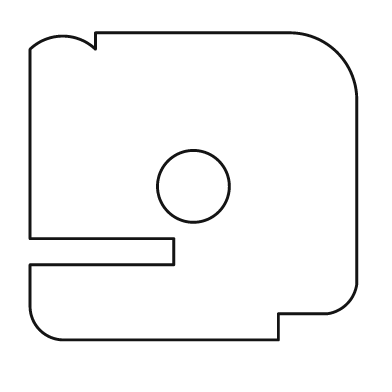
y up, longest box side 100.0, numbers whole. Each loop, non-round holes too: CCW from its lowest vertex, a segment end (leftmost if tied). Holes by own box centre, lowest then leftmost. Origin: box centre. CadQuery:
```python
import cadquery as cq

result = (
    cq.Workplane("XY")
    .moveTo(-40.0, -47.0)
    .lineTo(26.0, -47.0)
    .lineTo(26.0, -39.0)
    .lineTo(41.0, -39.0)
    .threePointArc((47.0, -36.0), (50.0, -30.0))
    .lineTo(50.0, 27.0)
    .threePointArc((44.0, 41.0), (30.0, 47.0))
    .lineTo(-30.0, 47.0)
    .lineTo(-30.0, 42.0)
    .threePointArc((-40.0, 46.0), (-50.0, 42.0))
    .lineTo(-50.0, -16.0)
    .lineTo(-6.0, -16.0)
    .lineTo(-6.0, -24.0)
    .lineTo(-50.0, -24.0)
    .lineTo(-50.0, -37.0)
    .threePointArc((-47.0, -44.0), (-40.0, -47.0))
    .close()
    .moveTo(0.0, 0.0)
    .circle(11.0)
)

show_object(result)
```